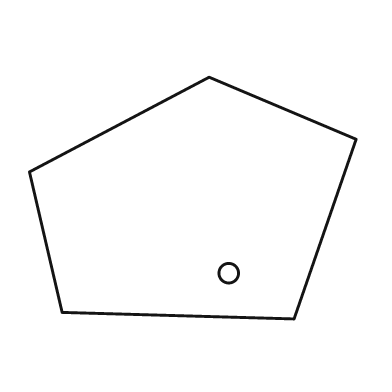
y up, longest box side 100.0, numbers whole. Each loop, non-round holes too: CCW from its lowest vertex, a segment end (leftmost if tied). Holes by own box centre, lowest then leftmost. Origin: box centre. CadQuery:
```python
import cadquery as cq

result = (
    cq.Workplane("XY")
    .moveTo(31.0, -37.0)
    .lineTo(50.0, 18.0)
    .lineTo(5.0, 37.0)
    .lineTo(-50.0, 8.0)
    .lineTo(-40.0, -35.0)
    .close()
    .moveTo(11.0, -23.0)
    .circle(3.0)
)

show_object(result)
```